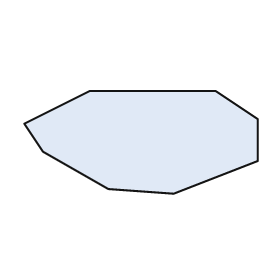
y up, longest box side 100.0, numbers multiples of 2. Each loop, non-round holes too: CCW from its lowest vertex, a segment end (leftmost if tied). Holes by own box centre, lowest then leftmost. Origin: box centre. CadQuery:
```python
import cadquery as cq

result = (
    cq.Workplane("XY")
    .moveTo(14.0, -22.0)
    .lineTo(50.0, -8.0)
    .lineTo(50.0, 10.0)
    .lineTo(32.0, 22.0)
    .lineTo(-22.0, 22.0)
    .lineTo(-50.0, 8.0)
    .lineTo(-42.0, -4.0)
    .lineTo(-14.0, -20.0)
    .close()
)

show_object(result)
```